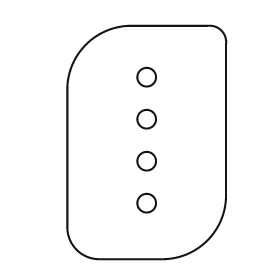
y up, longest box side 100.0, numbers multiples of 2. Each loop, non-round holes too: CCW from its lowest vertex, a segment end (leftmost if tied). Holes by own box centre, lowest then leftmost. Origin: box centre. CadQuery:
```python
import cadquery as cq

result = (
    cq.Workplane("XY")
    .moveTo(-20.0, -50.0)
    .lineTo(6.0, -50.0)
    .threePointArc((26.0, -42.0), (34.0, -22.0))
    .lineTo(34.0, 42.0)
    .threePointArc((32.0, 48.0), (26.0, 50.0))
    .lineTo(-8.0, 50.0)
    .threePointArc((-26.0, 42.0), (-34.0, 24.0))
    .lineTo(-34.0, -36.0)
    .threePointArc((-30.0, -46.0), (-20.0, -50.0))
    .close()
    .moveTo(0.0, -26.0)
    .circle(4.0)
    .moveTo(0.0, -8.0)
    .circle(4.0)
    .moveTo(0.0, 10.0)
    .circle(4.0)
    .moveTo(0.0, 28.0)
    .circle(4.0)
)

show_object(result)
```